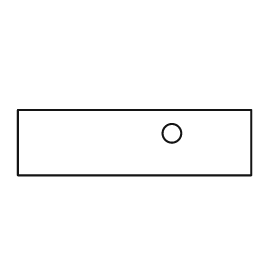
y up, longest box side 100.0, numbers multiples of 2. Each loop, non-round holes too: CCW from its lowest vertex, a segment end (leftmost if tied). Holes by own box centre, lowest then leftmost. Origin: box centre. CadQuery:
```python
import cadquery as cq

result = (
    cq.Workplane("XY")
    .moveTo(-50.0, -14.0)
    .lineTo(50.0, -14.0)
    .lineTo(50.0, 14.0)
    .lineTo(-50.0, 14.0)
    .close()
    .moveTo(16.0, 4.0)
    .circle(4.0)
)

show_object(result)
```